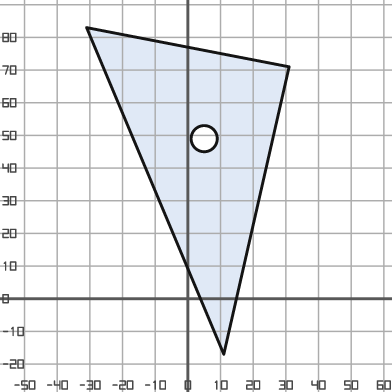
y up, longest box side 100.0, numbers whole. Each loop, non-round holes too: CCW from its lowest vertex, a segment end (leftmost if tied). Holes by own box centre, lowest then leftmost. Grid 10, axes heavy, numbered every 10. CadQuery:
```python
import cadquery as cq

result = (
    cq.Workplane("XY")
    .moveTo(11.0, -17.0)
    .lineTo(31.0, 71.0)
    .lineTo(-31.0, 83.0)
    .close()
    .moveTo(5.0, 49.0)
    .circle(4.0)
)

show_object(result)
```